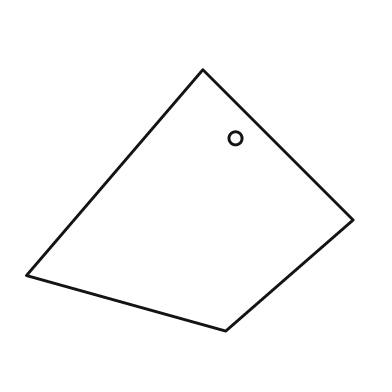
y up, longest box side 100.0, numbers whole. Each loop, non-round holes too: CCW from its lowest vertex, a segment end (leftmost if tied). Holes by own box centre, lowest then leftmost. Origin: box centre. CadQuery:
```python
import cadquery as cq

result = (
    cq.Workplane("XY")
    .moveTo(11.0, -40.0)
    .lineTo(50.0, -6.0)
    .lineTo(4.0, 40.0)
    .lineTo(-50.0, -23.0)
    .close()
    .moveTo(14.0, 19.0)
    .circle(2.0)
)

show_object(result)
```